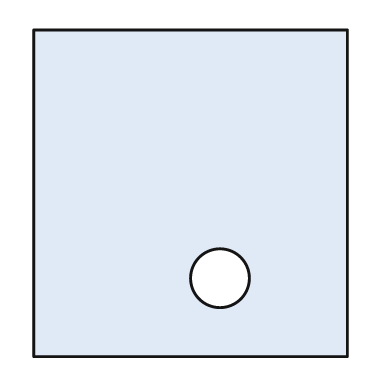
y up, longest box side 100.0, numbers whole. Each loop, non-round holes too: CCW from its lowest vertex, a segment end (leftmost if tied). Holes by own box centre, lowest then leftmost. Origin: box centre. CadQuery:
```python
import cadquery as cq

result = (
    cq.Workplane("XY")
    .moveTo(-48.0, -50.0)
    .lineTo(48.0, -50.0)
    .lineTo(48.0, 50.0)
    .lineTo(-48.0, 50.0)
    .close()
    .moveTo(9.0, -26.0)
    .circle(9.0)
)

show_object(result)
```